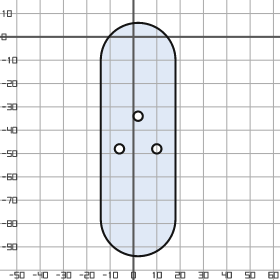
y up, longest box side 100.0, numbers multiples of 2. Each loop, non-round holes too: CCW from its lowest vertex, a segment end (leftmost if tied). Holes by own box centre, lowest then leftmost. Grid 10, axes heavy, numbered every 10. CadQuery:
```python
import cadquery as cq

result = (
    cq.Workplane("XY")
    .moveTo(-14.0, -78.0)
    .threePointArc((2.0, -94.0), (18.0, -78.0))
    .lineTo(18.0, -10.0)
    .threePointArc((2.0, 6.0), (-14.0, -10.0))
    .close()
    .moveTo(-6.0, -48.0)
    .circle(2.0)
    .moveTo(10.0, -48.0)
    .circle(2.0)
    .moveTo(2.0, -34.0)
    .circle(2.0)
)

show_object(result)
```